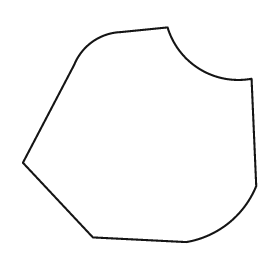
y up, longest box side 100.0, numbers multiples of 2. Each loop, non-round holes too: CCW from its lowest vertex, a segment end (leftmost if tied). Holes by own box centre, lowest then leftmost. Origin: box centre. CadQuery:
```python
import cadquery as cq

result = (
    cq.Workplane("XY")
    .moveTo(20.0, -46.0)
    .threePointArc((38.0, -38.0), (50.0, -22.0))
    .lineTo(48.0, 24.0)
    .threePointArc((26.0, 28.0), (12.0, 46.0))
    .lineTo(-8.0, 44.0)
    .threePointArc((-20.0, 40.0), (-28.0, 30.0))
    .lineTo(-50.0, -12.0)
    .lineTo(-20.0, -44.0)
    .close()
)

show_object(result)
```